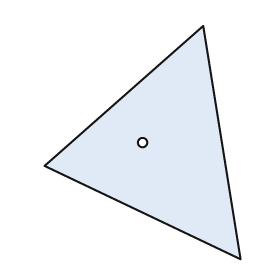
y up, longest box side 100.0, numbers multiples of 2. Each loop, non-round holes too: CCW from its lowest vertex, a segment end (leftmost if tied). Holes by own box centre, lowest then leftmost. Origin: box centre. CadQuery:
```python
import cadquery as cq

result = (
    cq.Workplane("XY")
    .moveTo(42.0, -50.0)
    .lineTo(26.0, 50.0)
    .lineTo(-42.0, -10.0)
    .close()
    .moveTo(0.0, 0.0)
    .circle(2.0)
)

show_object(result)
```